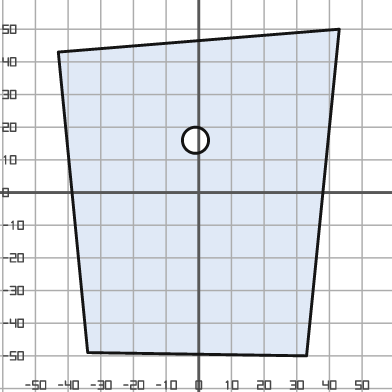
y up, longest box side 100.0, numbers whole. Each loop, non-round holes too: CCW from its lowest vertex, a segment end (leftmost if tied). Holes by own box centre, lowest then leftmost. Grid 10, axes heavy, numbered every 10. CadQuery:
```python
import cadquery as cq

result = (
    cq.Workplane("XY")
    .moveTo(33.0, -50.0)
    .lineTo(43.0, 50.0)
    .lineTo(-43.0, 43.0)
    .lineTo(-34.0, -49.0)
    .close()
    .moveTo(-1.0, 16.0)
    .circle(4.0)
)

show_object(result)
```